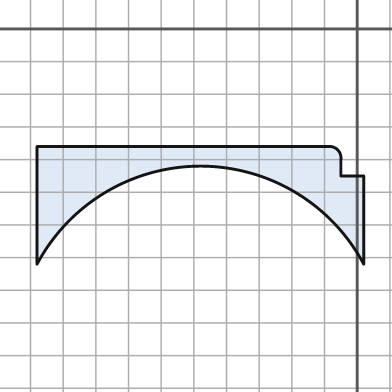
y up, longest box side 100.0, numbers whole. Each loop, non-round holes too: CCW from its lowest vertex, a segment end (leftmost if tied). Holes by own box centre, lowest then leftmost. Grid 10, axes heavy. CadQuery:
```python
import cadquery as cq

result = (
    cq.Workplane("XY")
    .moveTo(-98.0, -72.0)
    .threePointArc((-48.0, -42.0), (2.0, -72.0))
    .lineTo(2.0, -45.0)
    .lineTo(-5.0, -45.0)
    .lineTo(-5.0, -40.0)
    .threePointArc((-6.0, -37.0), (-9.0, -36.0))
    .lineTo(-98.0, -36.0)
    .close()
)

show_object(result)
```